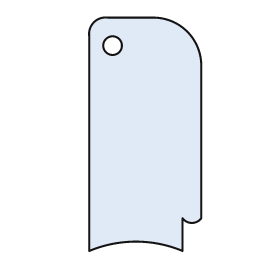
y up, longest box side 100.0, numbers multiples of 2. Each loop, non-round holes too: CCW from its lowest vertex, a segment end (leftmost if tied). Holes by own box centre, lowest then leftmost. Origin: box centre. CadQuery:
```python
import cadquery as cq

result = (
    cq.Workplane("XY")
    .moveTo(-24.0, -50.0)
    .threePointArc((-4.0, -46.0), (16.0, -50.0))
    .lineTo(16.0, -36.0)
    .threePointArc((20.0, -38.0), (24.0, -36.0))
    .lineTo(24.0, 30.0)
    .threePointArc((18.0, 44.0), (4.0, 50.0))
    .lineTo(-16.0, 50.0)
    .threePointArc((-22.0, 48.0), (-24.0, 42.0))
    .close()
    .moveTo(-14.0, 38.0)
    .circle(4.0)
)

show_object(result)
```